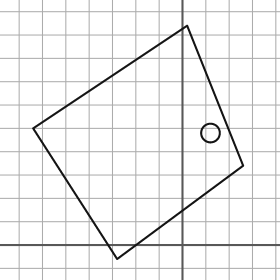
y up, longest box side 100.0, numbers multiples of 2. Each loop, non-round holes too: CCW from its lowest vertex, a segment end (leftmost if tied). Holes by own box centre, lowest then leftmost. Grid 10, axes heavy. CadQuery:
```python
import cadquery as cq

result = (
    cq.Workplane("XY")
    .moveTo(-28.0, -6.0)
    .lineTo(26.0, 34.0)
    .lineTo(2.0, 94.0)
    .lineTo(-64.0, 50.0)
    .close()
    .moveTo(12.0, 48.0)
    .circle(4.0)
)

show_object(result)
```